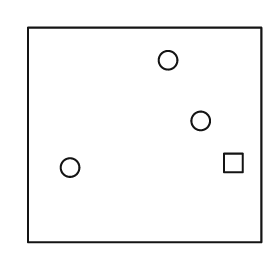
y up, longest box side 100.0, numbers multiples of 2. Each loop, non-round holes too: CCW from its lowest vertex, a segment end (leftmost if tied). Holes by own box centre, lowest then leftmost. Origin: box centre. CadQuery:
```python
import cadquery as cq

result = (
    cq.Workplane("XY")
    .moveTo(-50.0, -46.0)
    .lineTo(50.0, -46.0)
    .lineTo(50.0, 46.0)
    .lineTo(-50.0, 46.0)
    .close()
    .moveTo(-32.0, -14.0)
    .circle(4.0)
    .moveTo(34.0, -16.0)
    .lineTo(42.0, -16.0)
    .lineTo(42.0, -8.0)
    .lineTo(34.0, -8.0)
    .close()
    .moveTo(24.0, 6.0)
    .circle(4.0)
    .moveTo(10.0, 32.0)
    .circle(4.0)
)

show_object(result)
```